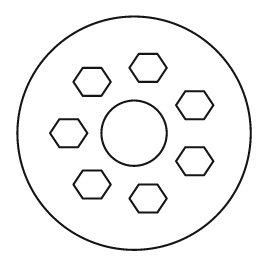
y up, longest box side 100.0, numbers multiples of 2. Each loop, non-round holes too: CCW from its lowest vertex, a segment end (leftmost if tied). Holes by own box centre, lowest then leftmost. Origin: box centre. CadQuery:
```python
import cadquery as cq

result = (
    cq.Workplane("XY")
    .moveTo(0.0, 0.0)
    .circle(50.0)
    .moveTo(2.0, -34.0)
    .lineTo(10.0, -34.0)
    .lineTo(14.0, -28.0)
    .lineTo(10.0, -22.0)
    .lineTo(2.0, -22.0)
    .lineTo(-2.0, -28.0)
    .close()
    .moveTo(-22.0, -28.0)
    .lineTo(-14.0, -28.0)
    .lineTo(-10.0, -22.0)
    .lineTo(-14.0, -16.0)
    .lineTo(-22.0, -16.0)
    .lineTo(-26.0, -22.0)
    .close()
    .moveTo(22.0, -18.0)
    .lineTo(30.0, -18.0)
    .lineTo(34.0, -12.0)
    .lineTo(30.0, -6.0)
    .lineTo(22.0, -6.0)
    .lineTo(18.0, -12.0)
    .close()
    .moveTo(-32.0, -6.0)
    .lineTo(-24.0, -6.0)
    .lineTo(-20.0, 0.0)
    .lineTo(-24.0, 6.0)
    .lineTo(-32.0, 6.0)
    .lineTo(-36.0, 0.0)
    .close()
    .moveTo(0.0, 0.0)
    .circle(14.0)
    .moveTo(22.0, 6.0)
    .lineTo(30.0, 6.0)
    .lineTo(34.0, 12.0)
    .lineTo(30.0, 18.0)
    .lineTo(22.0, 18.0)
    .lineTo(18.0, 12.0)
    .close()
    .moveTo(-22.0, 16.0)
    .lineTo(-14.0, 16.0)
    .lineTo(-10.0, 22.0)
    .lineTo(-14.0, 28.0)
    .lineTo(-22.0, 28.0)
    .lineTo(-26.0, 22.0)
    .close()
    .moveTo(2.0, 22.0)
    .lineTo(10.0, 22.0)
    .lineTo(14.0, 28.0)
    .lineTo(10.0, 34.0)
    .lineTo(2.0, 34.0)
    .lineTo(-2.0, 28.0)
    .close()
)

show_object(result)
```